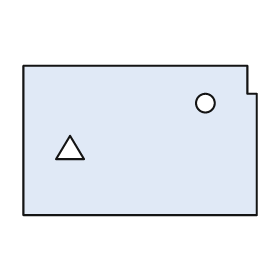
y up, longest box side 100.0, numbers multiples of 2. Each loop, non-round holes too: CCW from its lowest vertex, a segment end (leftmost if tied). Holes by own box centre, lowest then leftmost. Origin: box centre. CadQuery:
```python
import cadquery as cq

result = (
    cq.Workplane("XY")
    .moveTo(-50.0, -32.0)
    .lineTo(50.0, -32.0)
    .lineTo(50.0, 20.0)
    .lineTo(46.0, 20.0)
    .lineTo(46.0, 32.0)
    .lineTo(-50.0, 32.0)
    .close()
    .moveTo(-36.0, -8.0)
    .lineTo(-24.0, -8.0)
    .lineTo(-30.0, 2.0)
    .close()
    .moveTo(28.0, 16.0)
    .circle(4.0)
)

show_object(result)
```